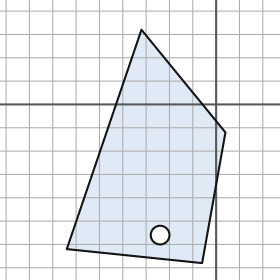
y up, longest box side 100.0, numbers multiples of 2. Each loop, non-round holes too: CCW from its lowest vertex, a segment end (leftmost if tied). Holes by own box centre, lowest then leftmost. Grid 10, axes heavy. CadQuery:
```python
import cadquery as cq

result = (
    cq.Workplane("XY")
    .moveTo(-6.0, -68.0)
    .lineTo(4.0, -12.0)
    .lineTo(-32.0, 32.0)
    .lineTo(-64.0, -62.0)
    .close()
    .moveTo(-24.0, -56.0)
    .circle(4.0)
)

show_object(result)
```